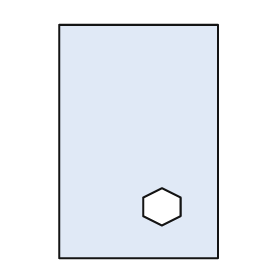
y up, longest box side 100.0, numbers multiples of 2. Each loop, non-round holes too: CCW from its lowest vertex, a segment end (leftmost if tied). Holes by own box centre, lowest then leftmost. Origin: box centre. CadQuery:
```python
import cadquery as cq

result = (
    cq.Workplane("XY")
    .moveTo(-34.0, -50.0)
    .lineTo(34.0, -50.0)
    .lineTo(34.0, 50.0)
    .lineTo(-34.0, 50.0)
    .close()
    .moveTo(10.0, -36.0)
    .lineTo(18.0, -32.0)
    .lineTo(18.0, -24.0)
    .lineTo(10.0, -20.0)
    .lineTo(2.0, -24.0)
    .lineTo(2.0, -32.0)
    .close()
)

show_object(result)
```